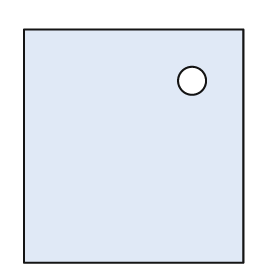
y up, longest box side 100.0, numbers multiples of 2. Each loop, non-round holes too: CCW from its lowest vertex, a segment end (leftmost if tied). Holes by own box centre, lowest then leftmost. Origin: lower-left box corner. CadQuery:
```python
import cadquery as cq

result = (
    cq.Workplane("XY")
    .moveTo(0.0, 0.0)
    .lineTo(94.0, 0.0)
    .lineTo(94.0, 100.0)
    .lineTo(0.0, 100.0)
    .close()
    .moveTo(72.0, 78.0)
    .circle(6.0)
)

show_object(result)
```